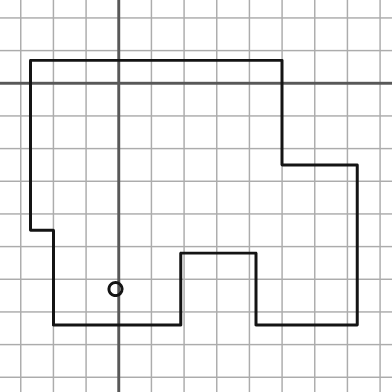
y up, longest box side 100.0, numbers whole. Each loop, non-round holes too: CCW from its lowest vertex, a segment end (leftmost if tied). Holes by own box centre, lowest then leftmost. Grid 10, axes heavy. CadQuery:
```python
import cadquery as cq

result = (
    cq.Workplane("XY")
    .moveTo(-20.0, -74.0)
    .lineTo(19.0, -74.0)
    .lineTo(19.0, -52.0)
    .lineTo(42.0, -52.0)
    .lineTo(42.0, -74.0)
    .lineTo(73.0, -74.0)
    .lineTo(73.0, -25.0)
    .lineTo(50.0, -25.0)
    .lineTo(50.0, 7.0)
    .lineTo(-27.0, 7.0)
    .lineTo(-27.0, -45.0)
    .lineTo(-20.0, -45.0)
    .close()
    .moveTo(-1.0, -63.0)
    .circle(2.0)
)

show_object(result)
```